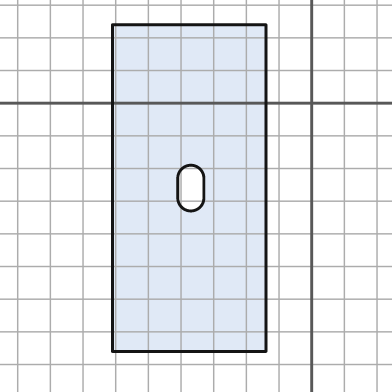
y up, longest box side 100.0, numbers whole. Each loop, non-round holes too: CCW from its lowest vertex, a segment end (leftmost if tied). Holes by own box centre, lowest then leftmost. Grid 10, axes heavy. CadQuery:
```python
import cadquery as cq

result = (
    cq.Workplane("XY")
    .moveTo(-61.0, -76.0)
    .lineTo(-14.0, -76.0)
    .lineTo(-14.0, 24.0)
    .lineTo(-61.0, 24.0)
    .close()
    .moveTo(-41.0, -29.0)
    .threePointArc((-37.0, -33.0), (-33.0, -29.0))
    .lineTo(-33.0, -23.0)
    .threePointArc((-37.0, -19.0), (-41.0, -23.0))
    .close()
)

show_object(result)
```